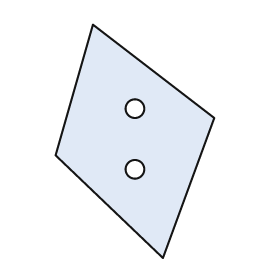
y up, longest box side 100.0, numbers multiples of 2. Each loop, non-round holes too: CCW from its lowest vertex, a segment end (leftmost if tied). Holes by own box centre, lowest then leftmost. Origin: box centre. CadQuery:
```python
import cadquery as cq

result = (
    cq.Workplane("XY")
    .moveTo(12.0, -50.0)
    .lineTo(34.0, 10.0)
    .lineTo(-18.0, 50.0)
    .lineTo(-34.0, -6.0)
    .close()
    .moveTo(0.0, -12.0)
    .circle(4.0)
    .moveTo(0.0, 14.0)
    .circle(4.0)
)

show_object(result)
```